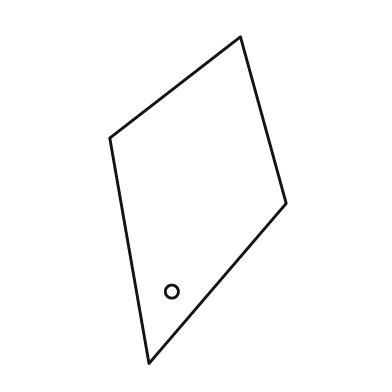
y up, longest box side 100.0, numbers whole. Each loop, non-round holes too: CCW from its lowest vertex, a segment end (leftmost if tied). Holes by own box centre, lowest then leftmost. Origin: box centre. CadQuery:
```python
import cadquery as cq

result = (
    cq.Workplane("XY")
    .moveTo(-15.0, -50.0)
    .lineTo(27.0, -1.0)
    .lineTo(13.0, 50.0)
    .lineTo(-27.0, 19.0)
    .close()
    .moveTo(-8.0, -28.0)
    .circle(2.0)
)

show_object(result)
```